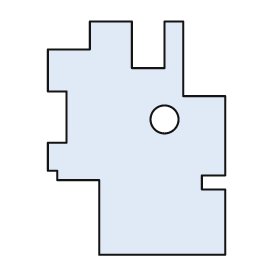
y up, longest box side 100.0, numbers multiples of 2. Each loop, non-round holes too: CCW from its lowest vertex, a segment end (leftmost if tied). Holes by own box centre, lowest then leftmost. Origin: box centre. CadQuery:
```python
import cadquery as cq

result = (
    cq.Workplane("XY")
    .moveTo(-16.0, -50.0)
    .lineTo(38.0, -50.0)
    .lineTo(38.0, -22.0)
    .lineTo(28.0, -22.0)
    .lineTo(28.0, -16.0)
    .lineTo(38.0, -16.0)
    .lineTo(38.0, 18.0)
    .lineTo(20.0, 18.0)
    .lineTo(20.0, 50.0)
    .lineTo(12.0, 50.0)
    .lineTo(12.0, 30.0)
    .lineTo(-2.0, 30.0)
    .lineTo(-2.0, 50.0)
    .lineTo(-20.0, 50.0)
    .lineTo(-20.0, 38.0)
    .lineTo(-38.0, 38.0)
    .lineTo(-38.0, 20.0)
    .lineTo(-30.0, 20.0)
    .lineTo(-30.0, -2.0)
    .lineTo(-38.0, -2.0)
    .lineTo(-38.0, -14.0)
    .lineTo(-34.0, -14.0)
    .lineTo(-34.0, -18.0)
    .lineTo(-16.0, -18.0)
    .close()
    .moveTo(12.0, 8.0)
    .circle(6.0)
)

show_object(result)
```